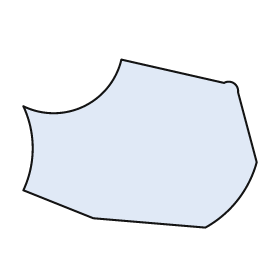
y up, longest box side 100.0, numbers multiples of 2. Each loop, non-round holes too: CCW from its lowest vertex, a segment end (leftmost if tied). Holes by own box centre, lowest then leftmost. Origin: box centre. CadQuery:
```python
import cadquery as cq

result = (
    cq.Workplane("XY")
    .moveTo(28.0, -36.0)
    .threePointArc((42.0, -24.0), (50.0, -8.0))
    .lineTo(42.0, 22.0)
    .threePointArc((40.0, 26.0), (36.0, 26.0))
    .lineTo(-8.0, 36.0)
    .threePointArc((-24.0, 16.0), (-50.0, 16.0))
    .threePointArc((-46.0, -2.0), (-50.0, -20.0))
    .lineTo(-20.0, -32.0)
    .close()
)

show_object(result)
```